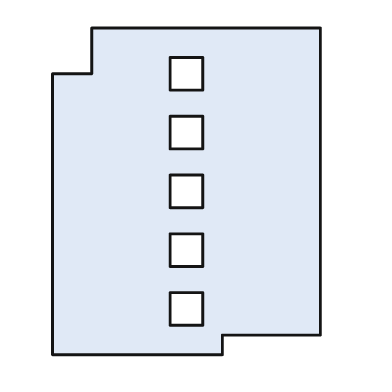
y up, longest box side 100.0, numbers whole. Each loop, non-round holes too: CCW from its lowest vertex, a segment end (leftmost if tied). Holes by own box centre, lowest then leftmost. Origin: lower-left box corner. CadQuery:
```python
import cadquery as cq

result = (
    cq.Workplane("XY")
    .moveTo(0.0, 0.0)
    .lineTo(52.0, 0.0)
    .lineTo(52.0, 6.0)
    .lineTo(82.0, 6.0)
    .lineTo(82.0, 100.0)
    .lineTo(12.0, 100.0)
    .lineTo(12.0, 86.0)
    .lineTo(0.0, 86.0)
    .close()
    .moveTo(36.0, 9.0)
    .lineTo(46.0, 9.0)
    .lineTo(46.0, 19.0)
    .lineTo(36.0, 19.0)
    .close()
    .moveTo(36.0, 27.0)
    .lineTo(46.0, 27.0)
    .lineTo(46.0, 37.0)
    .lineTo(36.0, 37.0)
    .close()
    .moveTo(36.0, 45.0)
    .lineTo(46.0, 45.0)
    .lineTo(46.0, 55.0)
    .lineTo(36.0, 55.0)
    .close()
    .moveTo(36.0, 63.0)
    .lineTo(46.0, 63.0)
    .lineTo(46.0, 73.0)
    .lineTo(36.0, 73.0)
    .close()
    .moveTo(36.0, 81.0)
    .lineTo(46.0, 81.0)
    .lineTo(46.0, 91.0)
    .lineTo(36.0, 91.0)
    .close()
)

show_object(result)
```